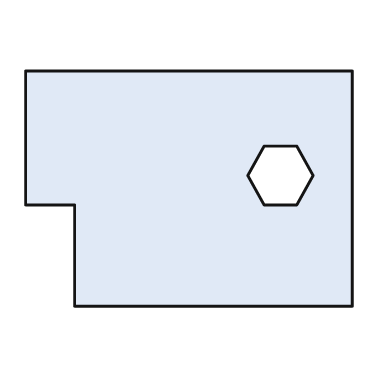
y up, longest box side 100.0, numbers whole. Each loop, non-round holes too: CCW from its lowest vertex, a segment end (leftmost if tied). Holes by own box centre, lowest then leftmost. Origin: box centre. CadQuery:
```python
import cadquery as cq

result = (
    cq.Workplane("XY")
    .moveTo(-35.0, -36.0)
    .lineTo(50.0, -36.0)
    .lineTo(50.0, 36.0)
    .lineTo(-50.0, 36.0)
    .lineTo(-50.0, -5.0)
    .lineTo(-35.0, -5.0)
    .close()
    .moveTo(23.0, -5.0)
    .lineTo(33.0, -5.0)
    .lineTo(38.0, 4.0)
    .lineTo(33.0, 13.0)
    .lineTo(23.0, 13.0)
    .lineTo(18.0, 4.0)
    .close()
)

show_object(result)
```